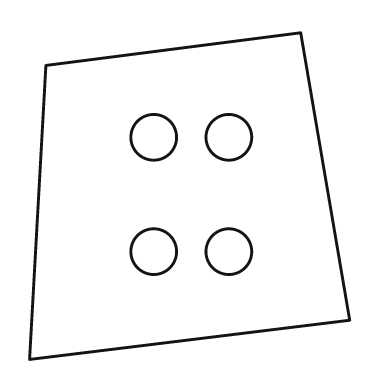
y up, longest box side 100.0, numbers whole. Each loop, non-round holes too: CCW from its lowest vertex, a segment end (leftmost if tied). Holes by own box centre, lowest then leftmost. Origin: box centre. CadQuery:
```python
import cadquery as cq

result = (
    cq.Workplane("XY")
    .moveTo(-49.0, -50.0)
    .lineTo(49.0, -38.0)
    .lineTo(34.0, 50.0)
    .lineTo(-44.0, 40.0)
    .close()
    .moveTo(-11.0, -17.0)
    .circle(7.0)
    .moveTo(12.0, -17.0)
    .circle(7.0)
    .moveTo(-11.0, 18.0)
    .circle(7.0)
    .moveTo(12.0, 18.0)
    .circle(7.0)
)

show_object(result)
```